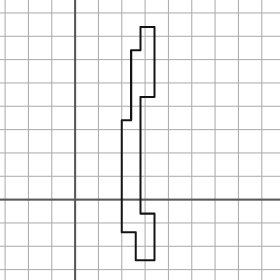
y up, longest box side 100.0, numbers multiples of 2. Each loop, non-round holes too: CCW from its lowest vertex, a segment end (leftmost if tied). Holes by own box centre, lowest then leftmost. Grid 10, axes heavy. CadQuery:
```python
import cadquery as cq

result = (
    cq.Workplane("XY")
    .moveTo(26.0, -26.0)
    .lineTo(34.0, -26.0)
    .lineTo(34.0, -6.0)
    .lineTo(28.0, -6.0)
    .lineTo(28.0, 44.0)
    .lineTo(34.0, 44.0)
    .lineTo(34.0, 74.0)
    .lineTo(28.0, 74.0)
    .lineTo(28.0, 64.0)
    .lineTo(24.0, 64.0)
    .lineTo(24.0, 34.0)
    .lineTo(20.0, 34.0)
    .lineTo(20.0, -14.0)
    .lineTo(26.0, -14.0)
    .close()
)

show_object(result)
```